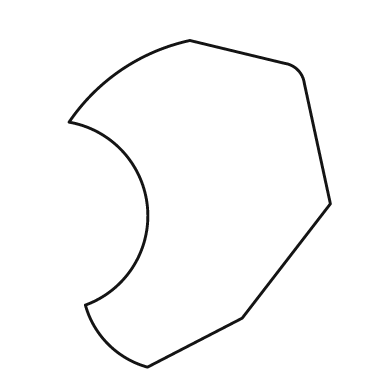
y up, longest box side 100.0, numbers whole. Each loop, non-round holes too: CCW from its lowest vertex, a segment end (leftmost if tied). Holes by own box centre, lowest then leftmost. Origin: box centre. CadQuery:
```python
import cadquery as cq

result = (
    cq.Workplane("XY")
    .moveTo(-16.0, -50.0)
    .lineTo(13.0, -35.0)
    .lineTo(40.0, 0.0)
    .lineTo(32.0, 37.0)
    .threePointArc((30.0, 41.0), (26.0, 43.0))
    .lineTo(-3.0, 50.0)
    .threePointArc((-24.0, 41.0), (-40.0, 25.0))
    .threePointArc((-16.0, -1.0), (-35.0, -31.0))
    .threePointArc((-28.0, -43.0), (-16.0, -50.0))
    .close()
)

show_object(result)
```